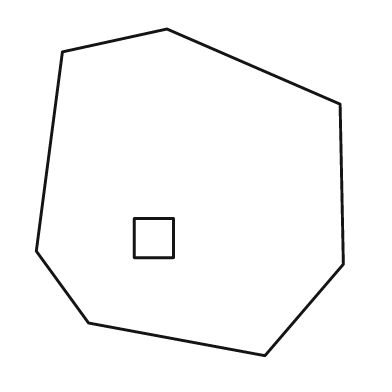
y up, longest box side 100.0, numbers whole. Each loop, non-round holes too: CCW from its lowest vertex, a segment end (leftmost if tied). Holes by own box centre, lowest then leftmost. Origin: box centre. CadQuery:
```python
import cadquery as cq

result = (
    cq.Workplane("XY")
    .moveTo(23.0, -50.0)
    .lineTo(47.0, -22.0)
    .lineTo(46.0, 27.0)
    .lineTo(-7.0, 50.0)
    .lineTo(-39.0, 43.0)
    .lineTo(-47.0, -18.0)
    .lineTo(-31.0, -40.0)
    .close()
    .moveTo(-17.0, -20.0)
    .lineTo(-5.0, -20.0)
    .lineTo(-5.0, -8.0)
    .lineTo(-17.0, -8.0)
    .close()
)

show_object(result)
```